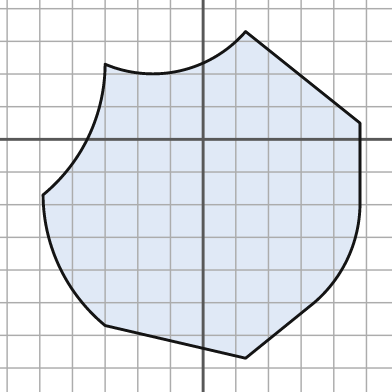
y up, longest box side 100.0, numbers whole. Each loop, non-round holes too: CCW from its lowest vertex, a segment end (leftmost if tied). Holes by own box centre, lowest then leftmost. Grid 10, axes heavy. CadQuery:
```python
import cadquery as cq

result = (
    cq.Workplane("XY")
    .moveTo(13.0, -67.0)
    .lineTo(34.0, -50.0)
    .threePointArc((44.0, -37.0), (48.0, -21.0))
    .lineTo(48.0, 5.0)
    .lineTo(13.0, 33.0)
    .threePointArc((-7.0, 21.0), (-30.0, 23.0))
    .threePointArc((-35.0, 1.0), (-49.0, -17.0))
    .threePointArc((-44.0, -39.0), (-30.0, -57.0))
    .close()
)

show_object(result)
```